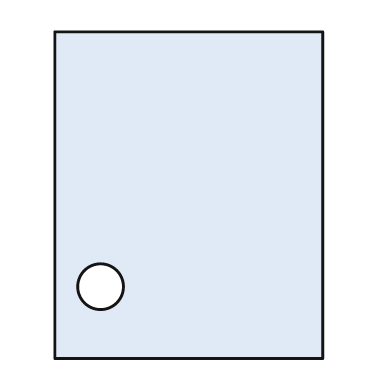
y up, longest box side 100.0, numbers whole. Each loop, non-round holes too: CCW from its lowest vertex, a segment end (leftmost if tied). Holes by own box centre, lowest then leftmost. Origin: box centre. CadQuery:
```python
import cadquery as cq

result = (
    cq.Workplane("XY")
    .moveTo(-41.0, -50.0)
    .lineTo(41.0, -50.0)
    .lineTo(41.0, 50.0)
    .lineTo(-41.0, 50.0)
    .close()
    .moveTo(-27.0, -28.0)
    .circle(7.0)
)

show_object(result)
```